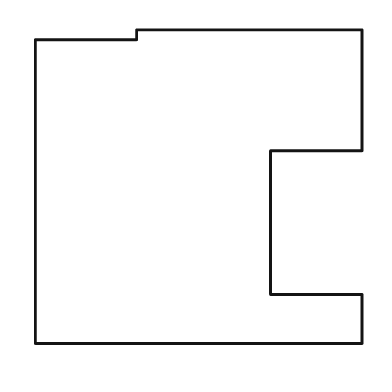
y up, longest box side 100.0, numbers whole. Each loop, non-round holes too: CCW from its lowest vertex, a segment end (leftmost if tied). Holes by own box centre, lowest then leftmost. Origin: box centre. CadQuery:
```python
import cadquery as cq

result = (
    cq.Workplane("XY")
    .moveTo(-50.0, -48.0)
    .lineTo(50.0, -48.0)
    .lineTo(50.0, -33.0)
    .lineTo(22.0, -33.0)
    .lineTo(22.0, 11.0)
    .lineTo(50.0, 11.0)
    .lineTo(50.0, 48.0)
    .lineTo(-19.0, 48.0)
    .lineTo(-19.0, 45.0)
    .lineTo(-50.0, 45.0)
    .close()
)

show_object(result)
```